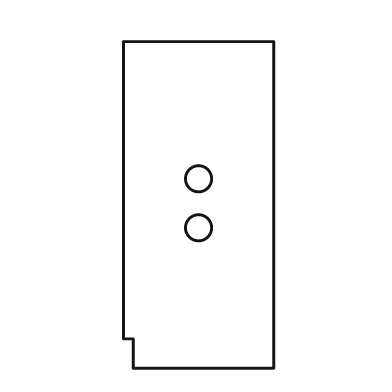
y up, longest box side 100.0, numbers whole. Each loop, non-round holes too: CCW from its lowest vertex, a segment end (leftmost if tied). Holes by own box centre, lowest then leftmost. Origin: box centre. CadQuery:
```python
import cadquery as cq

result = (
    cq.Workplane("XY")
    .moveTo(-20.0, -50.0)
    .lineTo(23.0, -50.0)
    .lineTo(23.0, 50.0)
    .lineTo(-23.0, 50.0)
    .lineTo(-23.0, -41.0)
    .lineTo(-20.0, -41.0)
    .close()
    .moveTo(0.0, -7.0)
    .circle(4.0)
    .moveTo(0.0, 8.0)
    .circle(4.0)
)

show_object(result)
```